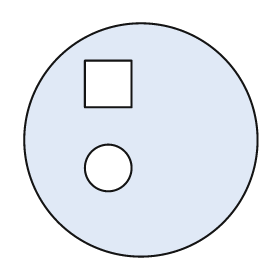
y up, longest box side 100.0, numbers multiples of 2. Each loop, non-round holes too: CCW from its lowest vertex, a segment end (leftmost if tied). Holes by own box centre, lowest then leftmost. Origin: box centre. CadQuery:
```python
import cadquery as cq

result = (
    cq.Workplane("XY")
    .moveTo(0.0, 0.0)
    .circle(50.0)
    .moveTo(-14.0, -12.0)
    .circle(10.0)
    .moveTo(-24.0, 14.0)
    .lineTo(-4.0, 14.0)
    .lineTo(-4.0, 34.0)
    .lineTo(-24.0, 34.0)
    .close()
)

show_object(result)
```